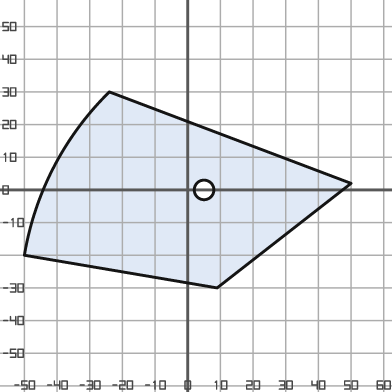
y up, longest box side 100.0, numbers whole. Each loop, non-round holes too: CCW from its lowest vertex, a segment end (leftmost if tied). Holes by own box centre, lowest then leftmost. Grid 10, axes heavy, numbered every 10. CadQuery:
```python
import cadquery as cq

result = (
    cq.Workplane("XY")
    .moveTo(9.0, -30.0)
    .lineTo(50.0, 2.0)
    .lineTo(-24.0, 30.0)
    .threePointArc((-41.0, 7.0), (-50.0, -20.0))
    .close()
    .moveTo(5.0, 0.0)
    .circle(3.0)
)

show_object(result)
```